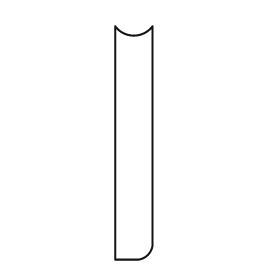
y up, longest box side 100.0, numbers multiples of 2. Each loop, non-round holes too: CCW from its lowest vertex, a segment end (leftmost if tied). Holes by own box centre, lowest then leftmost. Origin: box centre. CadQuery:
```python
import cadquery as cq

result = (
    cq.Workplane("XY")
    .moveTo(-8.0, -50.0)
    .lineTo(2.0, -50.0)
    .threePointArc((6.0, -48.0), (8.0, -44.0))
    .lineTo(8.0, 50.0)
    .threePointArc((0.0, 46.0), (-8.0, 50.0))
    .close()
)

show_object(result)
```